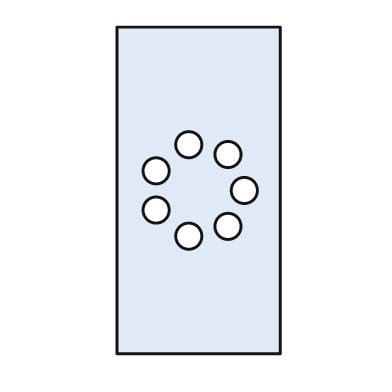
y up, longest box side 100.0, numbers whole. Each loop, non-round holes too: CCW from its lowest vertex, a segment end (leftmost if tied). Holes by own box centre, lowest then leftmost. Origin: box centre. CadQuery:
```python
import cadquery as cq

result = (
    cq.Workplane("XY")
    .moveTo(-25.0, -50.0)
    .lineTo(25.0, -50.0)
    .lineTo(25.0, 50.0)
    .lineTo(-25.0, 50.0)
    .close()
    .moveTo(-3.0, -14.0)
    .circle(4.0)
    .moveTo(9.0, -11.0)
    .circle(4.0)
    .moveTo(-13.0, -6.0)
    .circle(4.0)
    .moveTo(14.0, 0.0)
    .circle(4.0)
    .moveTo(-13.0, 6.0)
    .circle(4.0)
    .moveTo(9.0, 11.0)
    .circle(4.0)
    .moveTo(-3.0, 14.0)
    .circle(4.0)
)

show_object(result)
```